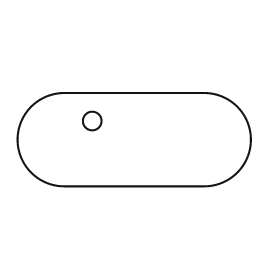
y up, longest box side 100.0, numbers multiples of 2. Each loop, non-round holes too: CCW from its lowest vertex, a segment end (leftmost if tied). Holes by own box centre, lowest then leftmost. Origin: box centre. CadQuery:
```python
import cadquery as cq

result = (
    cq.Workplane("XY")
    .moveTo(-30.0, -20.0)
    .lineTo(30.0, -20.0)
    .threePointArc((50.0, 0.0), (30.0, 20.0))
    .lineTo(-30.0, 20.0)
    .threePointArc((-50.0, 0.0), (-30.0, -20.0))
    .close()
    .moveTo(-18.0, 8.0)
    .circle(4.0)
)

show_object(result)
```